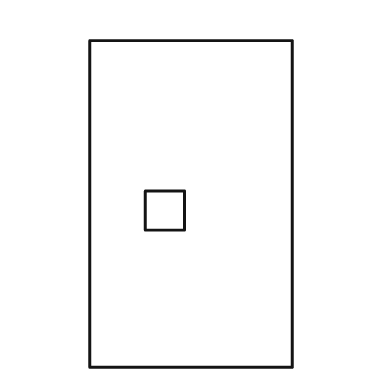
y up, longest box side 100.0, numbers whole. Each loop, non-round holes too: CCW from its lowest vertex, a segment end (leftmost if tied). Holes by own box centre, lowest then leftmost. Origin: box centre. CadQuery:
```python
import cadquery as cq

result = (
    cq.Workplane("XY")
    .moveTo(-31.0, -50.0)
    .lineTo(31.0, -50.0)
    .lineTo(31.0, 50.0)
    .lineTo(-31.0, 50.0)
    .close()
    .moveTo(-14.0, -8.0)
    .lineTo(-2.0, -8.0)
    .lineTo(-2.0, 4.0)
    .lineTo(-14.0, 4.0)
    .close()
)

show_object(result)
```